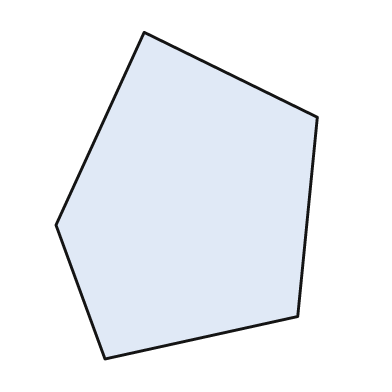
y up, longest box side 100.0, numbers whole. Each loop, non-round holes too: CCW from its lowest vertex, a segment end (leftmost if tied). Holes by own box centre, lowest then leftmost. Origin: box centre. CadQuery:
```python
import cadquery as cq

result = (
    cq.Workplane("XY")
    .moveTo(-25.0, -50.0)
    .lineTo(34.0, -37.0)
    .lineTo(40.0, 24.0)
    .lineTo(-13.0, 50.0)
    .lineTo(-40.0, -9.0)
    .close()
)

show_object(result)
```